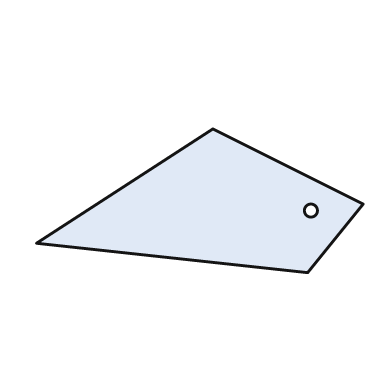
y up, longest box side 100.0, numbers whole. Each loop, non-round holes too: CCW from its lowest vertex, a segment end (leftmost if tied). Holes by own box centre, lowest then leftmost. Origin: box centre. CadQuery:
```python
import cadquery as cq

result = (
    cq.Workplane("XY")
    .moveTo(33.0, -22.0)
    .lineTo(50.0, -1.0)
    .lineTo(4.0, 22.0)
    .lineTo(-50.0, -13.0)
    .close()
    .moveTo(34.0, -3.0)
    .circle(2.0)
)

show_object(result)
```